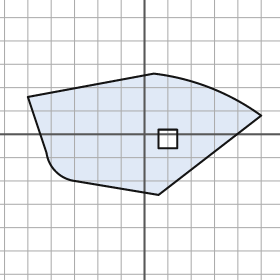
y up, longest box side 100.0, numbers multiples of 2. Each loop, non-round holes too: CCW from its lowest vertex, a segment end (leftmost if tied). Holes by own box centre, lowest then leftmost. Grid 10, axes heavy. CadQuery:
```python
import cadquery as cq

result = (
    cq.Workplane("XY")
    .moveTo(6.0, -26.0)
    .lineTo(50.0, 8.0)
    .threePointArc((28.0, 20.0), (4.0, 26.0))
    .lineTo(-50.0, 16.0)
    .lineTo(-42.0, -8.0)
    .threePointArc((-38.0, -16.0), (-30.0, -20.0))
    .close()
    .moveTo(6.0, -6.0)
    .lineTo(14.0, -6.0)
    .lineTo(14.0, 2.0)
    .lineTo(6.0, 2.0)
    .close()
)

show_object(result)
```